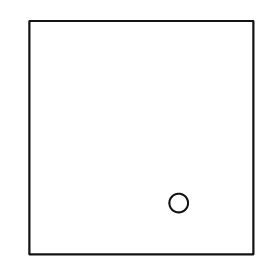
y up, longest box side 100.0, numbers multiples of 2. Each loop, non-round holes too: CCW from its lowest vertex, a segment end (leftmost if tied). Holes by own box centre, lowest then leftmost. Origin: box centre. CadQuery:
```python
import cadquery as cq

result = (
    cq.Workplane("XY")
    .moveTo(-48.0, -50.0)
    .lineTo(48.0, -50.0)
    .lineTo(48.0, 50.0)
    .lineTo(-48.0, 50.0)
    .close()
    .moveTo(16.0, -28.0)
    .circle(4.0)
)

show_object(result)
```